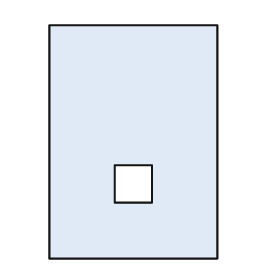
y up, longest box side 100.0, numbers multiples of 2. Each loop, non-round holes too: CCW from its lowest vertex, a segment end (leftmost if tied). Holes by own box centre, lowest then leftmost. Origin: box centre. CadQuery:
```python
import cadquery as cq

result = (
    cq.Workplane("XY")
    .moveTo(-36.0, -50.0)
    .lineTo(36.0, -50.0)
    .lineTo(36.0, 50.0)
    .lineTo(-36.0, 50.0)
    .close()
    .moveTo(-8.0, -26.0)
    .lineTo(8.0, -26.0)
    .lineTo(8.0, -10.0)
    .lineTo(-8.0, -10.0)
    .close()
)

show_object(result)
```